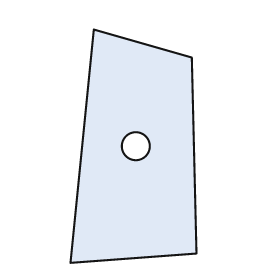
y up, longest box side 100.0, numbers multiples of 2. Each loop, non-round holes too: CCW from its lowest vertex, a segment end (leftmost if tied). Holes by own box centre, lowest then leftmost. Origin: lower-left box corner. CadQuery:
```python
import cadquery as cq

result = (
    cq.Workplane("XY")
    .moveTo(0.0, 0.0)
    .lineTo(54.0, 4.0)
    .lineTo(52.0, 88.0)
    .lineTo(10.0, 100.0)
    .close()
    .moveTo(28.0, 50.0)
    .circle(6.0)
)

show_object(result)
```